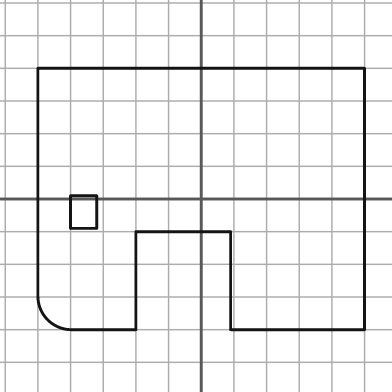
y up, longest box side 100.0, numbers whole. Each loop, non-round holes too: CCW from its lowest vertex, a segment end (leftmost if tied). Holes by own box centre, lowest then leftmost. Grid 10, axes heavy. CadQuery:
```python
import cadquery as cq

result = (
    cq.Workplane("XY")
    .moveTo(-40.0, -40.0)
    .lineTo(-20.0, -40.0)
    .lineTo(-20.0, -10.0)
    .lineTo(9.0, -10.0)
    .lineTo(9.0, -40.0)
    .lineTo(50.0, -40.0)
    .lineTo(50.0, 40.0)
    .lineTo(-50.0, 40.0)
    .lineTo(-50.0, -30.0)
    .threePointArc((-47.0, -37.0), (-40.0, -40.0))
    .close()
    .moveTo(-40.0, -9.0)
    .lineTo(-32.0, -9.0)
    .lineTo(-32.0, 1.0)
    .lineTo(-40.0, 1.0)
    .close()
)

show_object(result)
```